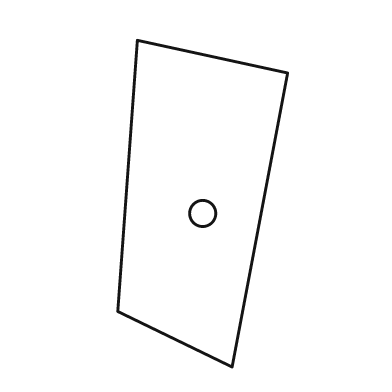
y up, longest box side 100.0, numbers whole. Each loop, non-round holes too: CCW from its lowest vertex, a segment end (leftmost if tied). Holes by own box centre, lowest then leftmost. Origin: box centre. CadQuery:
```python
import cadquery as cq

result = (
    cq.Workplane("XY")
    .moveTo(9.0, -50.0)
    .lineTo(26.0, 40.0)
    .lineTo(-20.0, 50.0)
    .lineTo(-26.0, -33.0)
    .close()
    .moveTo(0.0, -3.0)
    .circle(4.0)
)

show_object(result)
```